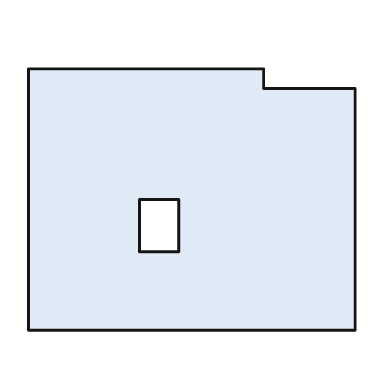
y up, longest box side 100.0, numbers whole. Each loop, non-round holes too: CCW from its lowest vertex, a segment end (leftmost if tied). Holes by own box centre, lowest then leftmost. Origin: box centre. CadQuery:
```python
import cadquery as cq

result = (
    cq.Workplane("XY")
    .moveTo(-50.0, -40.0)
    .lineTo(50.0, -40.0)
    .lineTo(50.0, 34.0)
    .lineTo(22.0, 34.0)
    .lineTo(22.0, 40.0)
    .lineTo(-50.0, 40.0)
    .close()
    .moveTo(-16.0, -16.0)
    .lineTo(-4.0, -16.0)
    .lineTo(-4.0, 0.0)
    .lineTo(-16.0, 0.0)
    .close()
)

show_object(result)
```